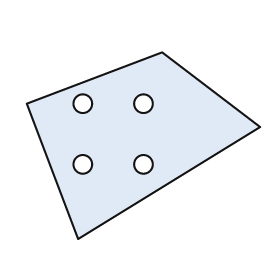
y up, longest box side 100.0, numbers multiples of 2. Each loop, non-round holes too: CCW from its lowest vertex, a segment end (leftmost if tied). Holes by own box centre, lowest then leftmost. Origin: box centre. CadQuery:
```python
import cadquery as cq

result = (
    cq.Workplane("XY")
    .moveTo(-28.0, -40.0)
    .lineTo(50.0, 8.0)
    .lineTo(8.0, 40.0)
    .lineTo(-50.0, 18.0)
    .close()
    .moveTo(-26.0, -8.0)
    .circle(4.0)
    .moveTo(0.0, -8.0)
    .circle(4.0)
    .moveTo(-26.0, 18.0)
    .circle(4.0)
    .moveTo(0.0, 18.0)
    .circle(4.0)
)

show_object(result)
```